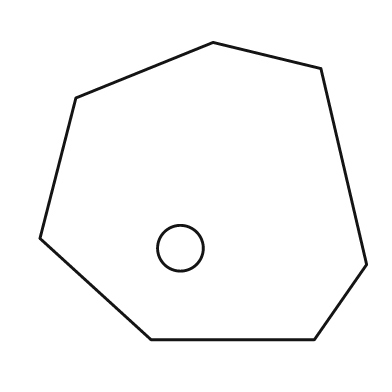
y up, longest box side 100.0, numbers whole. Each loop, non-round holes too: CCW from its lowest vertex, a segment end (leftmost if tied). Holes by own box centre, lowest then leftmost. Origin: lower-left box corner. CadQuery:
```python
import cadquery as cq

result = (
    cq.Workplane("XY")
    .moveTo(34.0, 0.0)
    .lineTo(84.0, 0.0)
    .lineTo(100.0, 23.0)
    .lineTo(86.0, 83.0)
    .lineTo(53.0, 91.0)
    .lineTo(11.0, 74.0)
    .lineTo(0.0, 31.0)
    .close()
    .moveTo(43.0, 28.0)
    .circle(7.0)
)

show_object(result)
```